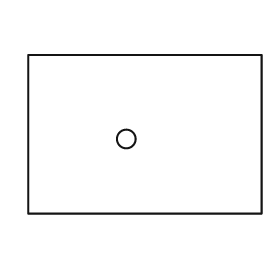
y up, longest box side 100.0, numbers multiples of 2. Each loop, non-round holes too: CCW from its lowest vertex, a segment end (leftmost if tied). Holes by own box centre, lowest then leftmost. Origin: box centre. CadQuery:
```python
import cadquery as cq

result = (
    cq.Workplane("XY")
    .moveTo(-50.0, -34.0)
    .lineTo(50.0, -34.0)
    .lineTo(50.0, 34.0)
    .lineTo(-50.0, 34.0)
    .close()
    .moveTo(-8.0, -2.0)
    .circle(4.0)
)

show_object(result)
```